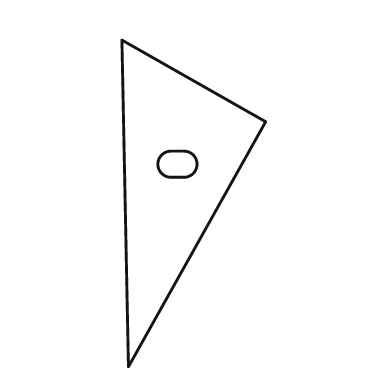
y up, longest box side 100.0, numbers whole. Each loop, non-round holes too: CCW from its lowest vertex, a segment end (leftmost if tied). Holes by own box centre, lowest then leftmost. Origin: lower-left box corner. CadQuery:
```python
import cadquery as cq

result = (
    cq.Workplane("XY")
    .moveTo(2.0, 0.0)
    .lineTo(44.0, 75.0)
    .lineTo(0.0, 100.0)
    .close()
    .moveTo(15.0, 58.0)
    .lineTo(19.0, 58.0)
    .threePointArc((23.0, 62.0), (19.0, 66.0))
    .lineTo(15.0, 66.0)
    .threePointArc((11.0, 62.0), (15.0, 58.0))
    .close()
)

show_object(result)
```